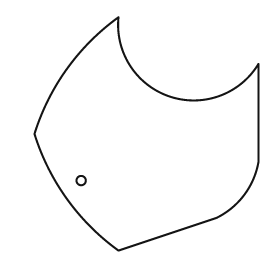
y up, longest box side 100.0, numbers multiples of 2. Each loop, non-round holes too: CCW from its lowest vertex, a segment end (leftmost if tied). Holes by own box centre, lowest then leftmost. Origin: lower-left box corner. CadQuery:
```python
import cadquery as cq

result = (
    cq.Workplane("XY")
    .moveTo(36.0, 0.0)
    .lineTo(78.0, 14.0)
    .threePointArc((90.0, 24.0), (96.0, 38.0))
    .lineTo(96.0, 80.0)
    .threePointArc((58.0, 66.0), (36.0, 100.0))
    .threePointArc((14.0, 78.0), (0.0, 50.0))
    .threePointArc((14.0, 22.0), (36.0, 0.0))
    .close()
    .moveTo(20.0, 30.0)
    .circle(2.0)
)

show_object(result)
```